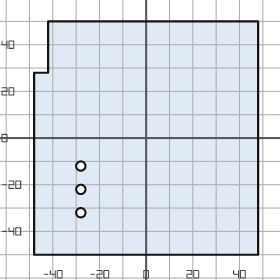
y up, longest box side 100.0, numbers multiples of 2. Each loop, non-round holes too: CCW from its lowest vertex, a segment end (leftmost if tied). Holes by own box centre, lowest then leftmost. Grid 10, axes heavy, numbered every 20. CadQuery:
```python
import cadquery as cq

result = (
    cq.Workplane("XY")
    .moveTo(-48.0, -50.0)
    .lineTo(48.0, -50.0)
    .lineTo(48.0, 50.0)
    .lineTo(-42.0, 50.0)
    .lineTo(-42.0, 28.0)
    .lineTo(-48.0, 28.0)
    .close()
    .moveTo(-28.0, -32.0)
    .circle(2.0)
    .moveTo(-28.0, -22.0)
    .circle(2.0)
    .moveTo(-28.0, -12.0)
    .circle(2.0)
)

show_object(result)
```